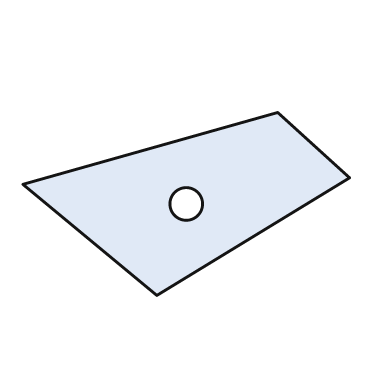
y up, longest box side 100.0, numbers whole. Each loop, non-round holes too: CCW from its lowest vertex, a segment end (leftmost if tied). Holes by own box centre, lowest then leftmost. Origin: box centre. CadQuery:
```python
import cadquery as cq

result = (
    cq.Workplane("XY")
    .moveTo(-9.0, -28.0)
    .lineTo(50.0, 8.0)
    .lineTo(28.0, 28.0)
    .lineTo(-50.0, 6.0)
    .close()
    .moveTo(0.0, 0.0)
    .circle(5.0)
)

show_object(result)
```